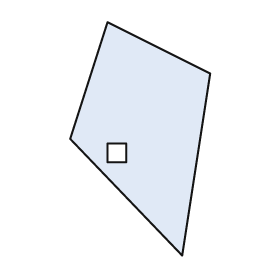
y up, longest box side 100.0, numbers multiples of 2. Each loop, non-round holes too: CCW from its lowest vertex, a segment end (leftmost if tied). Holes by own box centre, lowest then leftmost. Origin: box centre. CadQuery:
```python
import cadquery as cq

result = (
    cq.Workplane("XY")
    .moveTo(18.0, -50.0)
    .lineTo(30.0, 28.0)
    .lineTo(-14.0, 50.0)
    .lineTo(-30.0, 0.0)
    .close()
    .moveTo(-14.0, -10.0)
    .lineTo(-6.0, -10.0)
    .lineTo(-6.0, -2.0)
    .lineTo(-14.0, -2.0)
    .close()
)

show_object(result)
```